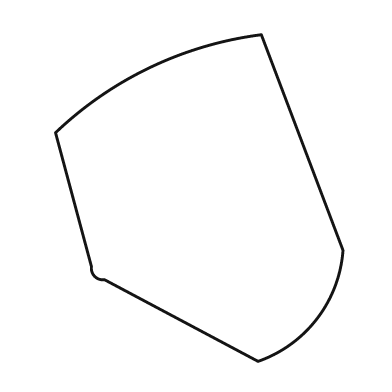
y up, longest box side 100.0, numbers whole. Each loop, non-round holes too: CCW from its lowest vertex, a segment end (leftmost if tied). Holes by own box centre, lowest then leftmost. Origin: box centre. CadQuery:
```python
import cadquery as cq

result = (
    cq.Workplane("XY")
    .moveTo(18.0, -50.0)
    .threePointArc((36.0, -37.0), (44.0, -16.0))
    .lineTo(19.0, 50.0)
    .threePointArc((-15.0, 40.0), (-44.0, 20.0))
    .lineTo(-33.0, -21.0)
    .threePointArc((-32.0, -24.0), (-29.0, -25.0))
    .close()
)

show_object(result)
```